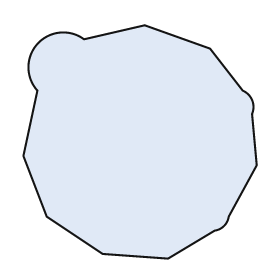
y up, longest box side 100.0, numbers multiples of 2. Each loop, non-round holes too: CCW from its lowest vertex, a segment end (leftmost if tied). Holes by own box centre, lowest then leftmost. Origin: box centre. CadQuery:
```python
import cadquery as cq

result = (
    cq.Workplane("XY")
    .moveTo(12.0, -50.0)
    .lineTo(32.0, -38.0)
    .threePointArc((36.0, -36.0), (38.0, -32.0))
    .lineTo(50.0, -10.0)
    .lineTo(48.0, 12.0)
    .threePointArc((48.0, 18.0), (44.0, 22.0))
    .lineTo(30.0, 40.0)
    .lineTo(2.0, 50.0)
    .lineTo(-24.0, 44.0)
    .threePointArc((-44.0, 42.0), (-44.0, 22.0))
    .lineTo(-50.0, -6.0)
    .lineTo(-40.0, -32.0)
    .lineTo(-16.0, -48.0)
    .close()
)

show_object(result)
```